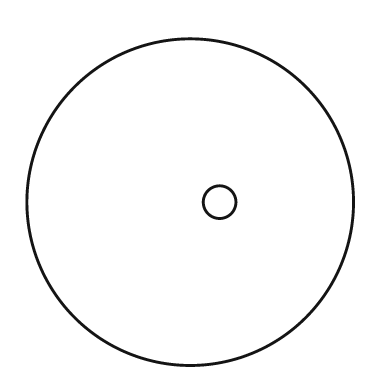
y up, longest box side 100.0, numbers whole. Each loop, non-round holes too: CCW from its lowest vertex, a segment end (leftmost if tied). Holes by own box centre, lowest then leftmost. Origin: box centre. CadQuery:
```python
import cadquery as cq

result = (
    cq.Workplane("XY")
    .moveTo(0.0, 0.0)
    .circle(50.0)
    .moveTo(9.0, 0.0)
    .circle(5.0)
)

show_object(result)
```